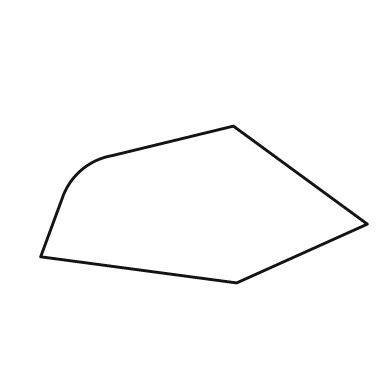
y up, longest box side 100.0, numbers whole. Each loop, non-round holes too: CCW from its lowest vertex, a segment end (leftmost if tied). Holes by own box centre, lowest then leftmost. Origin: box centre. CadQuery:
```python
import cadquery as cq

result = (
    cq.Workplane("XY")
    .moveTo(10.0, -24.0)
    .lineTo(50.0, -6.0)
    .lineTo(9.0, 24.0)
    .lineTo(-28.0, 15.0)
    .threePointArc((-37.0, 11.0), (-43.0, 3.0))
    .lineTo(-50.0, -16.0)
    .close()
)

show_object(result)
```